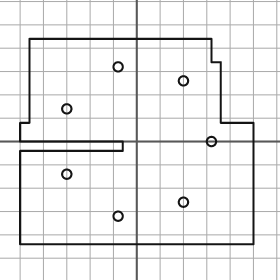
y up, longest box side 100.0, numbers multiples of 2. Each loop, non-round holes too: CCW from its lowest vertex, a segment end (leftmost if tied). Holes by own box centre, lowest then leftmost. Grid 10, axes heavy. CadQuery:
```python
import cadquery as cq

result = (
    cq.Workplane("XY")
    .moveTo(-50.0, -44.0)
    .lineTo(50.0, -44.0)
    .lineTo(50.0, 8.0)
    .lineTo(36.0, 8.0)
    .lineTo(36.0, 34.0)
    .lineTo(32.0, 34.0)
    .lineTo(32.0, 44.0)
    .lineTo(-46.0, 44.0)
    .lineTo(-46.0, 8.0)
    .lineTo(-50.0, 8.0)
    .lineTo(-50.0, 0.0)
    .lineTo(-6.0, 0.0)
    .lineTo(-6.0, -4.0)
    .lineTo(-50.0, -4.0)
    .close()
    .moveTo(-8.0, -32.0)
    .circle(2.0)
    .moveTo(20.0, -26.0)
    .circle(2.0)
    .moveTo(-30.0, -14.0)
    .circle(2.0)
    .moveTo(32.0, 0.0)
    .circle(2.0)
    .moveTo(-30.0, 14.0)
    .circle(2.0)
    .moveTo(20.0, 26.0)
    .circle(2.0)
    .moveTo(-8.0, 32.0)
    .circle(2.0)
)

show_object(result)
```